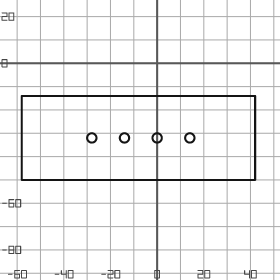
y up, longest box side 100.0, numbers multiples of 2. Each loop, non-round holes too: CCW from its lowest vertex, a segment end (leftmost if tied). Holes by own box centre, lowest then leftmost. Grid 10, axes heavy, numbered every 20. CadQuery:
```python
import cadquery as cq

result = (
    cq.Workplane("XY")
    .moveTo(-58.0, -50.0)
    .lineTo(42.0, -50.0)
    .lineTo(42.0, -14.0)
    .lineTo(-58.0, -14.0)
    .close()
    .moveTo(-28.0, -32.0)
    .circle(2.0)
    .moveTo(-14.0, -32.0)
    .circle(2.0)
    .moveTo(0.0, -32.0)
    .circle(2.0)
    .moveTo(14.0, -32.0)
    .circle(2.0)
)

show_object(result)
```